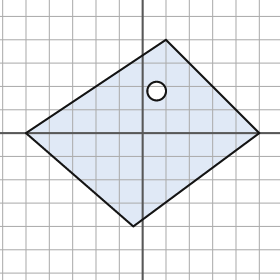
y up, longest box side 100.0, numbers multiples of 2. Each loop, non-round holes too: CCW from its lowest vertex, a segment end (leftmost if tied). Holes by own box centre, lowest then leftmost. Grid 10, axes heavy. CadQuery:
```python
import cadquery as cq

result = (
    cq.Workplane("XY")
    .moveTo(-4.0, -40.0)
    .lineTo(50.0, 0.0)
    .lineTo(10.0, 40.0)
    .lineTo(-50.0, 0.0)
    .close()
    .moveTo(6.0, 18.0)
    .circle(4.0)
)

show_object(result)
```